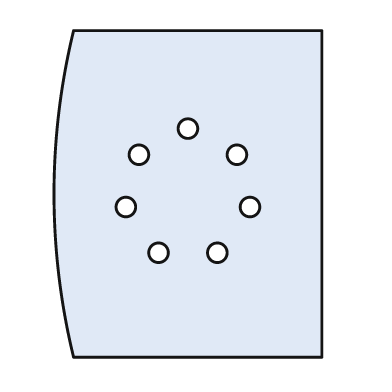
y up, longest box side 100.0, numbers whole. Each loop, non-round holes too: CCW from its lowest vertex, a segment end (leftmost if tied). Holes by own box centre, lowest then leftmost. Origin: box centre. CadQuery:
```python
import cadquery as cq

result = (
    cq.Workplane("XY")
    .moveTo(-35.0, -50.0)
    .lineTo(41.0, -50.0)
    .lineTo(41.0, 50.0)
    .lineTo(-35.0, 50.0)
    .threePointArc((-41.0, 0.0), (-35.0, -50.0))
    .close()
    .moveTo(-9.0, -18.0)
    .circle(3.0)
    .moveTo(9.0, -18.0)
    .circle(3.0)
    .moveTo(-19.0, -4.0)
    .circle(3.0)
    .moveTo(19.0, -4.0)
    .circle(3.0)
    .moveTo(-15.0, 12.0)
    .circle(3.0)
    .moveTo(15.0, 12.0)
    .circle(3.0)
    .moveTo(0.0, 20.0)
    .circle(3.0)
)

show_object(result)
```